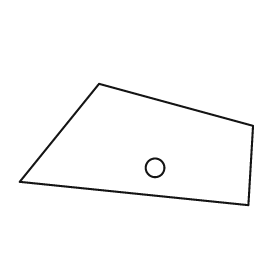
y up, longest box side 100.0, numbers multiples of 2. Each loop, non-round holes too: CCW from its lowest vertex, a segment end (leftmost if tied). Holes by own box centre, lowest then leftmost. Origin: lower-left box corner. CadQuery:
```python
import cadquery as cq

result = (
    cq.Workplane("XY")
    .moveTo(98.0, 0.0)
    .lineTo(100.0, 34.0)
    .lineTo(34.0, 52.0)
    .lineTo(0.0, 10.0)
    .close()
    .moveTo(58.0, 16.0)
    .circle(4.0)
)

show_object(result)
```